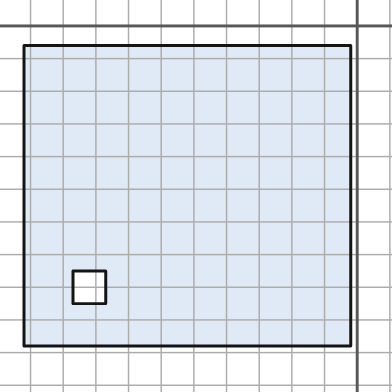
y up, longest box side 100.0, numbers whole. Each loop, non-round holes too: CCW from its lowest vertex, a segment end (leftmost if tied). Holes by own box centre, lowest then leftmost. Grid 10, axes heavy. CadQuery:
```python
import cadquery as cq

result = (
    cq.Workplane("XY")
    .moveTo(-102.0, -98.0)
    .lineTo(-2.0, -98.0)
    .lineTo(-2.0, -6.0)
    .lineTo(-102.0, -6.0)
    .close()
    .moveTo(-87.0, -85.0)
    .lineTo(-77.0, -85.0)
    .lineTo(-77.0, -75.0)
    .lineTo(-87.0, -75.0)
    .close()
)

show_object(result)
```